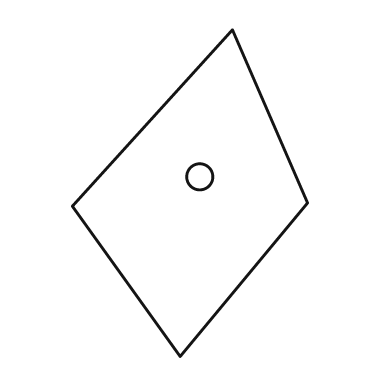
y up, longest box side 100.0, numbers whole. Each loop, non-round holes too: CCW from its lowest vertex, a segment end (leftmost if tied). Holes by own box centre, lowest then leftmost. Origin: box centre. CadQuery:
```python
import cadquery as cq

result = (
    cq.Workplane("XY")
    .moveTo(-3.0, -50.0)
    .lineTo(36.0, -3.0)
    .lineTo(13.0, 50.0)
    .lineTo(-36.0, -4.0)
    .close()
    .moveTo(3.0, 5.0)
    .circle(4.0)
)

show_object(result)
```